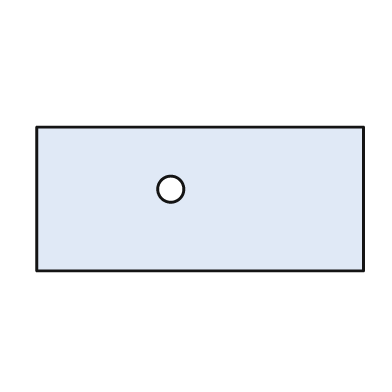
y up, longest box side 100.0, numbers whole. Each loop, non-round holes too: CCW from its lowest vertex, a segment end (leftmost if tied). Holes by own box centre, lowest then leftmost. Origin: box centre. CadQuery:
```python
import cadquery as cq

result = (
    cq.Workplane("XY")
    .moveTo(-50.0, -22.0)
    .lineTo(50.0, -22.0)
    .lineTo(50.0, 22.0)
    .lineTo(-50.0, 22.0)
    .close()
    .moveTo(-9.0, 3.0)
    .circle(4.0)
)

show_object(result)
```